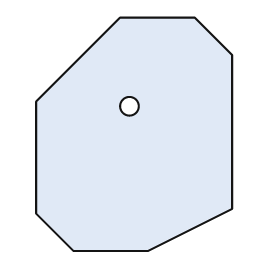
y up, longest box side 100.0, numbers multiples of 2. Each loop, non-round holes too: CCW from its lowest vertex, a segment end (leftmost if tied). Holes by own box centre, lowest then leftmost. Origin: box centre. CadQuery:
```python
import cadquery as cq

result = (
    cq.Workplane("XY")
    .moveTo(-26.0, -50.0)
    .lineTo(6.0, -50.0)
    .lineTo(42.0, -32.0)
    .lineTo(42.0, 34.0)
    .lineTo(26.0, 50.0)
    .lineTo(-6.0, 50.0)
    .lineTo(-42.0, 14.0)
    .lineTo(-42.0, -34.0)
    .close()
    .moveTo(-2.0, 12.0)
    .circle(4.0)
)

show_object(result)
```